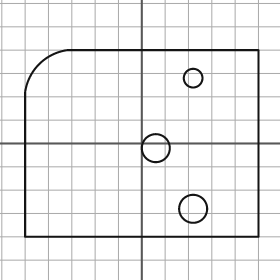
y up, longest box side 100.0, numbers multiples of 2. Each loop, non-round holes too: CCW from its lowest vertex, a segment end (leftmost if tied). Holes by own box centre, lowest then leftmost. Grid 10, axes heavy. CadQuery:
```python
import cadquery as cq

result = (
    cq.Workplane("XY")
    .moveTo(-50.0, -40.0)
    .lineTo(50.0, -40.0)
    .lineTo(50.0, 40.0)
    .lineTo(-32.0, 40.0)
    .threePointArc((-44.0, 34.0), (-50.0, 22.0))
    .close()
    .moveTo(22.0, -28.0)
    .circle(6.0)
    .moveTo(6.0, -2.0)
    .circle(6.0)
    .moveTo(22.0, 28.0)
    .circle(4.0)
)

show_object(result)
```